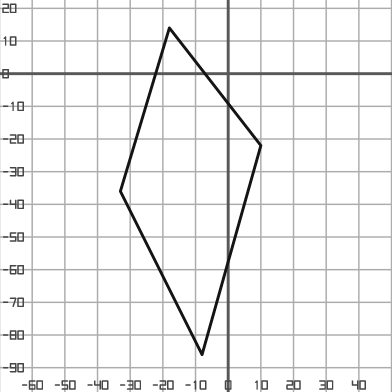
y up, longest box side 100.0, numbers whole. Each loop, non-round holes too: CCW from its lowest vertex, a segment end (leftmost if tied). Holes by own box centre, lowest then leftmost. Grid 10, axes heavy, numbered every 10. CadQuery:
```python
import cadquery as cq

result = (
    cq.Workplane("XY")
    .moveTo(-8.0, -86.0)
    .lineTo(10.0, -22.0)
    .lineTo(-18.0, 14.0)
    .lineTo(-33.0, -36.0)
    .close()
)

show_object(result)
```